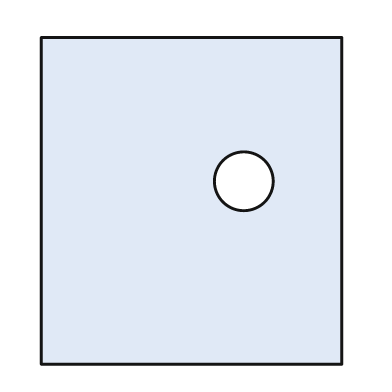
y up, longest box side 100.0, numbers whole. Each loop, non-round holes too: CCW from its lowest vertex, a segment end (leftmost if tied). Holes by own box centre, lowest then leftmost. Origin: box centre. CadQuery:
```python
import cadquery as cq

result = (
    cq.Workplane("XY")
    .moveTo(-46.0, -50.0)
    .lineTo(46.0, -50.0)
    .lineTo(46.0, 50.0)
    .lineTo(-46.0, 50.0)
    .close()
    .moveTo(16.0, 6.0)
    .circle(9.0)
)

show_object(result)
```